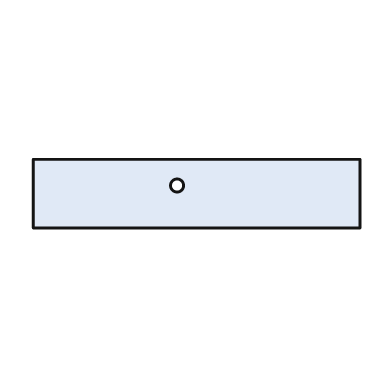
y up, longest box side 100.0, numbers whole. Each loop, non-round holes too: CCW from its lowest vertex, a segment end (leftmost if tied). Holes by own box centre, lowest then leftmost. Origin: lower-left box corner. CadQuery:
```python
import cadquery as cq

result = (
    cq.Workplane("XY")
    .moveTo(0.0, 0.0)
    .lineTo(100.0, 0.0)
    .lineTo(100.0, 21.0)
    .lineTo(0.0, 21.0)
    .close()
    .moveTo(44.0, 13.0)
    .circle(2.0)
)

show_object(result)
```